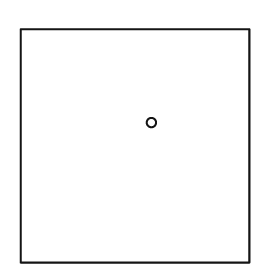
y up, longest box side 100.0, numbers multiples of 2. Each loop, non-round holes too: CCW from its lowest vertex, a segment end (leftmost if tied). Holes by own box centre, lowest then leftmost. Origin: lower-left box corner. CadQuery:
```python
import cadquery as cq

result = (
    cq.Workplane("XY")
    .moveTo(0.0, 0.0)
    .lineTo(98.0, 0.0)
    .lineTo(98.0, 100.0)
    .lineTo(0.0, 100.0)
    .close()
    .moveTo(56.0, 60.0)
    .circle(2.0)
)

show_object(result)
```